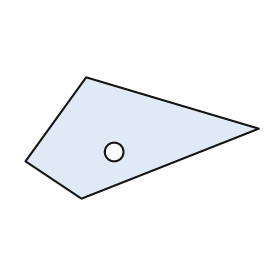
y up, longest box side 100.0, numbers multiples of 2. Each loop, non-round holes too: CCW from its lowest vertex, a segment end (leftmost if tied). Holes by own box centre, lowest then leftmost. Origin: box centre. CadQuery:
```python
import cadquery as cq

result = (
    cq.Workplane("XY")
    .moveTo(-26.0, -26.0)
    .lineTo(50.0, 4.0)
    .lineTo(-24.0, 26.0)
    .lineTo(-50.0, -10.0)
    .close()
    .moveTo(-12.0, -6.0)
    .circle(4.0)
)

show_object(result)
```